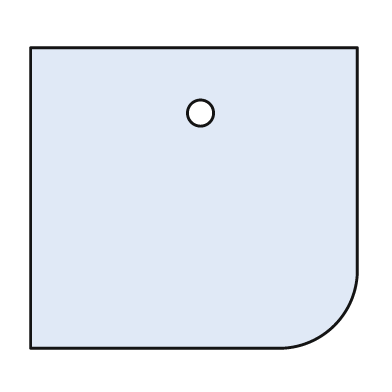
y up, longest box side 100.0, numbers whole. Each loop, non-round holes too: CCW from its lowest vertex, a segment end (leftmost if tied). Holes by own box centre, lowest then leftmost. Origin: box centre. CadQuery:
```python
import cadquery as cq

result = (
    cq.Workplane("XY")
    .moveTo(-50.0, -46.0)
    .lineTo(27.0, -46.0)
    .threePointArc((43.0, -39.0), (50.0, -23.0))
    .lineTo(50.0, 46.0)
    .lineTo(-50.0, 46.0)
    .close()
    .moveTo(2.0, 26.0)
    .circle(4.0)
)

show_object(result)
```